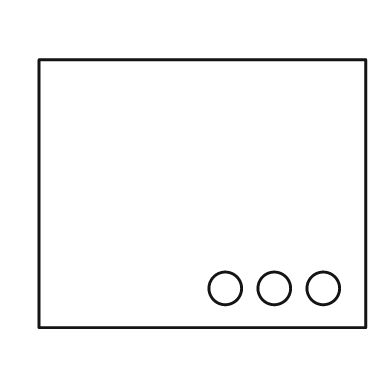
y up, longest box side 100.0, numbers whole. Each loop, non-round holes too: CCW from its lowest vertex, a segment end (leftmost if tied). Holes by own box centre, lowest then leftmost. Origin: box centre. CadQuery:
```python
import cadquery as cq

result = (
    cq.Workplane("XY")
    .moveTo(-50.0, -41.0)
    .lineTo(50.0, -41.0)
    .lineTo(50.0, 41.0)
    .lineTo(-50.0, 41.0)
    .close()
    .moveTo(7.0, -29.0)
    .circle(5.0)
    .moveTo(22.0, -29.0)
    .circle(5.0)
    .moveTo(37.0, -29.0)
    .circle(5.0)
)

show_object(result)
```